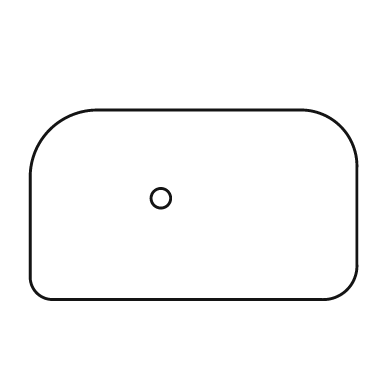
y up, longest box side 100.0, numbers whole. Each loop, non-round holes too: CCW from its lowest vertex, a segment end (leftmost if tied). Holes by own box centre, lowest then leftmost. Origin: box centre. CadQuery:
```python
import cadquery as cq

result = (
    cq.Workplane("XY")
    .moveTo(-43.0, -29.0)
    .lineTo(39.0, -29.0)
    .threePointArc((47.0, -26.0), (50.0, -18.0))
    .lineTo(50.0, 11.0)
    .threePointArc((45.0, 24.0), (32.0, 29.0))
    .lineTo(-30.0, 29.0)
    .threePointArc((-44.0, 23.0), (-50.0, 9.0))
    .lineTo(-50.0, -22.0)
    .threePointArc((-48.0, -27.0), (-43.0, -29.0))
    .close()
    .moveTo(-10.0, 2.0)
    .circle(3.0)
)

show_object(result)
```